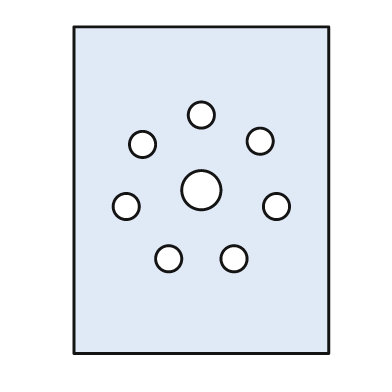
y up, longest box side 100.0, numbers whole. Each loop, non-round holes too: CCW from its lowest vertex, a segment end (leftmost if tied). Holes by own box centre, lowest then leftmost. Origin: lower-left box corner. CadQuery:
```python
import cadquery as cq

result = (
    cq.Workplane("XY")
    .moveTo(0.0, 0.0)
    .lineTo(78.0, 0.0)
    .lineTo(78.0, 100.0)
    .lineTo(0.0, 100.0)
    .close()
    .moveTo(29.0, 29.0)
    .circle(4.0)
    .moveTo(49.0, 29.0)
    .circle(4.0)
    .moveTo(16.0, 45.0)
    .circle(4.0)
    .moveTo(62.0, 45.0)
    .circle(4.0)
    .moveTo(39.0, 50.0)
    .circle(6.0)
    .moveTo(21.0, 64.0)
    .circle(4.0)
    .moveTo(57.0, 65.0)
    .circle(4.0)
    .moveTo(39.0, 73.0)
    .circle(4.0)
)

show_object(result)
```